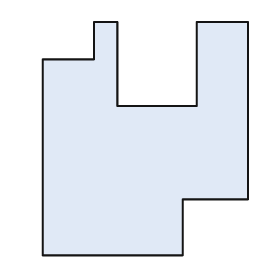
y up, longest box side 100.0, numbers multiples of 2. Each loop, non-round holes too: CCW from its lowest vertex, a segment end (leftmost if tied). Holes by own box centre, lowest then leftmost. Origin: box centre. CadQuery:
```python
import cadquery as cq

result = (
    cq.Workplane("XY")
    .moveTo(-44.0, -50.0)
    .lineTo(16.0, -50.0)
    .lineTo(16.0, -26.0)
    .lineTo(44.0, -26.0)
    .lineTo(44.0, 50.0)
    .lineTo(22.0, 50.0)
    .lineTo(22.0, 14.0)
    .lineTo(-12.0, 14.0)
    .lineTo(-12.0, 50.0)
    .lineTo(-22.0, 50.0)
    .lineTo(-22.0, 34.0)
    .lineTo(-44.0, 34.0)
    .close()
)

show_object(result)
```